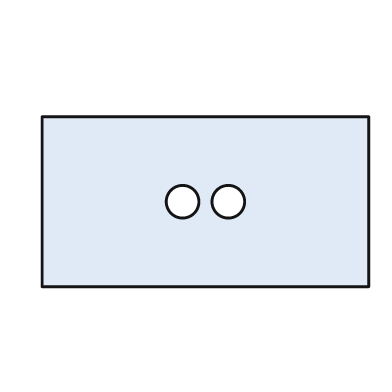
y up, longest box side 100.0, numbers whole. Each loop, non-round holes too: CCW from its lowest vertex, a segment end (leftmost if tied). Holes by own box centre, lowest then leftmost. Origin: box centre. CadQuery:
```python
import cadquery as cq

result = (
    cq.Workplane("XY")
    .moveTo(-50.0, -26.0)
    .lineTo(50.0, -26.0)
    .lineTo(50.0, 26.0)
    .lineTo(-50.0, 26.0)
    .close()
    .moveTo(-7.0, 0.0)
    .circle(5.0)
    .moveTo(7.0, 0.0)
    .circle(5.0)
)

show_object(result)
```